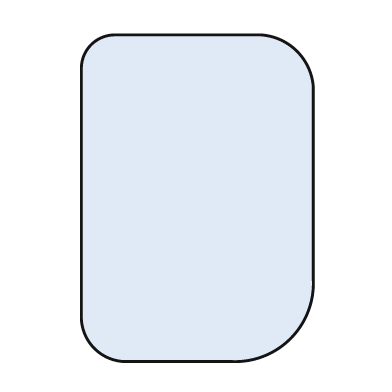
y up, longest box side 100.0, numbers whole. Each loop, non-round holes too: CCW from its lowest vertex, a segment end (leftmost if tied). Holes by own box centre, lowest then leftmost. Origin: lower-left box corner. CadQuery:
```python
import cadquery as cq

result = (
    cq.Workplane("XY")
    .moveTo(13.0, 0.0)
    .lineTo(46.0, 0.0)
    .threePointArc((64.0, 7.0), (71.0, 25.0))
    .lineTo(71.0, 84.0)
    .threePointArc((66.0, 95.0), (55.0, 100.0))
    .lineTo(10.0, 100.0)
    .threePointArc((3.0, 97.0), (0.0, 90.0))
    .lineTo(0.0, 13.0)
    .threePointArc((4.0, 4.0), (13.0, 0.0))
    .close()
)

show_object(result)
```